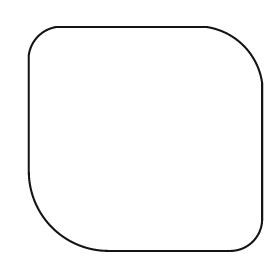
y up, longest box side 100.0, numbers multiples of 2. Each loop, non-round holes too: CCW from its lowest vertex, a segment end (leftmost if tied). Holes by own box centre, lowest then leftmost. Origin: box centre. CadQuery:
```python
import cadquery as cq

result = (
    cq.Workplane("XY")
    .moveTo(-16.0, -48.0)
    .lineTo(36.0, -48.0)
    .threePointArc((46.0, -44.0), (50.0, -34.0))
    .lineTo(50.0, 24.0)
    .threePointArc((42.0, 40.0), (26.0, 48.0))
    .lineTo(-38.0, 48.0)
    .threePointArc((-46.0, 44.0), (-50.0, 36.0))
    .lineTo(-50.0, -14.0)
    .threePointArc((-40.0, -38.0), (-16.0, -48.0))
    .close()
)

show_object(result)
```